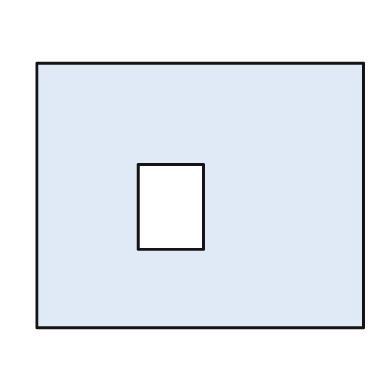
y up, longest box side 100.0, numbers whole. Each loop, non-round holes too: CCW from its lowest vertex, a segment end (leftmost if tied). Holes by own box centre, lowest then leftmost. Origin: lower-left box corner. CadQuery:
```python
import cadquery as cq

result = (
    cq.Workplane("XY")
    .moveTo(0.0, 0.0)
    .lineTo(100.0, 0.0)
    .lineTo(100.0, 81.0)
    .lineTo(0.0, 81.0)
    .close()
    .moveTo(31.0, 24.0)
    .lineTo(51.0, 24.0)
    .lineTo(51.0, 50.0)
    .lineTo(31.0, 50.0)
    .close()
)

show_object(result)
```